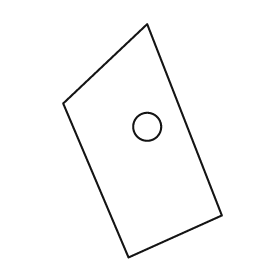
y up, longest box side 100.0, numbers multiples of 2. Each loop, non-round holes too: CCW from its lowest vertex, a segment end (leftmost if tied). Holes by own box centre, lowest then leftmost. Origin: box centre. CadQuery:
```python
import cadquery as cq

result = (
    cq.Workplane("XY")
    .moveTo(-6.0, -50.0)
    .lineTo(34.0, -32.0)
    .lineTo(2.0, 50.0)
    .lineTo(-34.0, 16.0)
    .close()
    .moveTo(2.0, 6.0)
    .circle(6.0)
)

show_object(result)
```